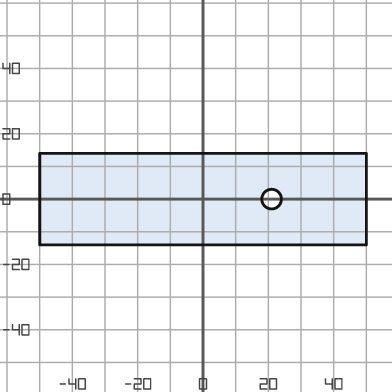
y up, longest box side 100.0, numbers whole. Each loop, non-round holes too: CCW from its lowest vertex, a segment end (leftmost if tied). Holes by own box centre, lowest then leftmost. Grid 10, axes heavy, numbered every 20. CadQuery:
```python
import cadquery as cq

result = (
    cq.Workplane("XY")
    .moveTo(-50.0, -14.0)
    .lineTo(50.0, -14.0)
    .lineTo(50.0, 14.0)
    .lineTo(-50.0, 14.0)
    .close()
    .moveTo(21.0, 0.0)
    .circle(3.0)
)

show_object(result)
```